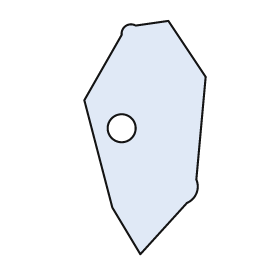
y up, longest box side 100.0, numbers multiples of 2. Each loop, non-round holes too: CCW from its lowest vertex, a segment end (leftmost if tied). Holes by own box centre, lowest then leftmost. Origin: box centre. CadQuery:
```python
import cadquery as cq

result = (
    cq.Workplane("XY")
    .moveTo(-2.0, -50.0)
    .lineTo(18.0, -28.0)
    .threePointArc((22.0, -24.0), (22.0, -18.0))
    .lineTo(26.0, 26.0)
    .lineTo(10.0, 50.0)
    .lineTo(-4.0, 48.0)
    .threePointArc((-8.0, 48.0), (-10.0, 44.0))
    .lineTo(-26.0, 16.0)
    .lineTo(-14.0, -30.0)
    .close()
    .moveTo(-10.0, 4.0)
    .circle(6.0)
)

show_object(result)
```